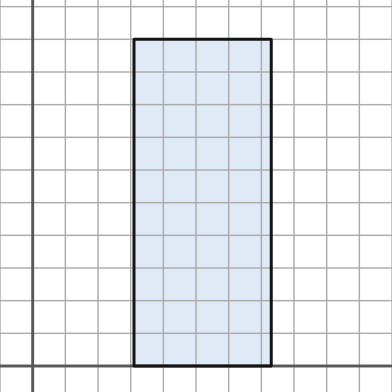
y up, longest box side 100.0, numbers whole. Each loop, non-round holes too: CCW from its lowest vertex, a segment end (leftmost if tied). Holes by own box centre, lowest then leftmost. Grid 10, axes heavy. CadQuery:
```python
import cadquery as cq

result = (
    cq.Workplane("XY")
    .moveTo(31.0, 0.0)
    .lineTo(73.0, 0.0)
    .lineTo(73.0, 100.0)
    .lineTo(31.0, 100.0)
    .close()
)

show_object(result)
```